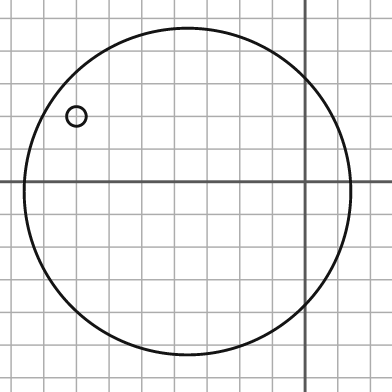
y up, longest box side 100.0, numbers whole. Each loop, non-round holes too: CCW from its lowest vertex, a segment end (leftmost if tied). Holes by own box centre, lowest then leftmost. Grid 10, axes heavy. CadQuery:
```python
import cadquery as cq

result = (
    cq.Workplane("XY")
    .moveTo(-36.0, -3.0)
    .circle(50.0)
    .moveTo(-70.0, 20.0)
    .circle(3.0)
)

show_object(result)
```